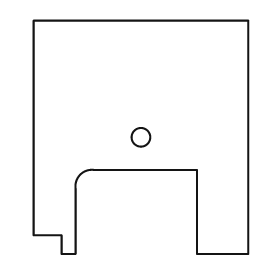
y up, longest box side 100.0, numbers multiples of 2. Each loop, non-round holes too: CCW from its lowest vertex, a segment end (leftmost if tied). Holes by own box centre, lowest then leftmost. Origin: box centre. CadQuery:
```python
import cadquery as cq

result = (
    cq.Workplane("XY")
    .moveTo(-34.0, -50.0)
    .lineTo(-28.0, -50.0)
    .lineTo(-28.0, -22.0)
    .threePointArc((-26.0, -16.0), (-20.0, -14.0))
    .lineTo(24.0, -14.0)
    .lineTo(24.0, -50.0)
    .lineTo(46.0, -50.0)
    .lineTo(46.0, 50.0)
    .lineTo(-46.0, 50.0)
    .lineTo(-46.0, -42.0)
    .lineTo(-34.0, -42.0)
    .close()
    .moveTo(0.0, 0.0)
    .circle(4.0)
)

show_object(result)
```